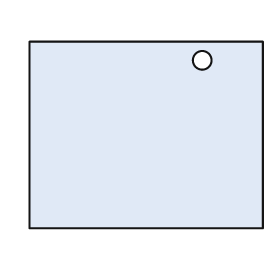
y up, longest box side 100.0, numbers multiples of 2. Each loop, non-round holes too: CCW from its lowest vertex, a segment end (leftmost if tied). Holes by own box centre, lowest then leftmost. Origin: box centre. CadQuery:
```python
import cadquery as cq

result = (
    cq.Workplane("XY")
    .moveTo(-50.0, -40.0)
    .lineTo(50.0, -40.0)
    .lineTo(50.0, 40.0)
    .lineTo(-50.0, 40.0)
    .close()
    .moveTo(24.0, 32.0)
    .circle(4.0)
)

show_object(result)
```